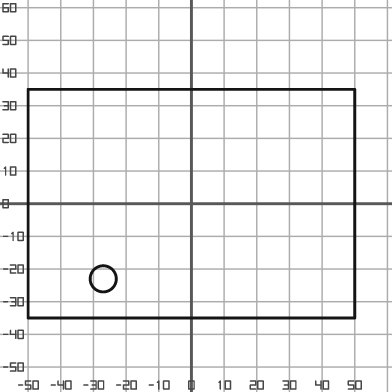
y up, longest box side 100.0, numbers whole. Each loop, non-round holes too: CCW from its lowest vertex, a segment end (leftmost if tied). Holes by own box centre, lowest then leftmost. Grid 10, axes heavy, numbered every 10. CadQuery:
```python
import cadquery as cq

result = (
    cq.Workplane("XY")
    .moveTo(-50.0, -35.0)
    .lineTo(50.0, -35.0)
    .lineTo(50.0, 35.0)
    .lineTo(-50.0, 35.0)
    .close()
    .moveTo(-27.0, -23.0)
    .circle(4.0)
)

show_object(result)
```